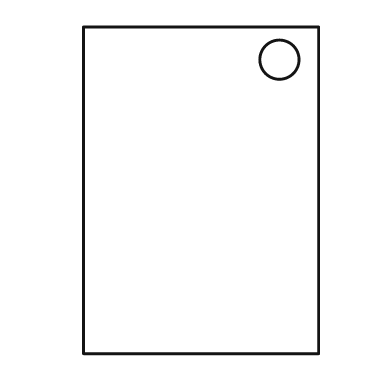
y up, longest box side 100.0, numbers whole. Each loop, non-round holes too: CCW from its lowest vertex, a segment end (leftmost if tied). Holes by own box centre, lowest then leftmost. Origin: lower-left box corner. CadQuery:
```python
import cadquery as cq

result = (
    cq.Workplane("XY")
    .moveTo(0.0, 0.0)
    .lineTo(72.0, 0.0)
    .lineTo(72.0, 100.0)
    .lineTo(0.0, 100.0)
    .close()
    .moveTo(60.0, 90.0)
    .circle(6.0)
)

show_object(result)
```